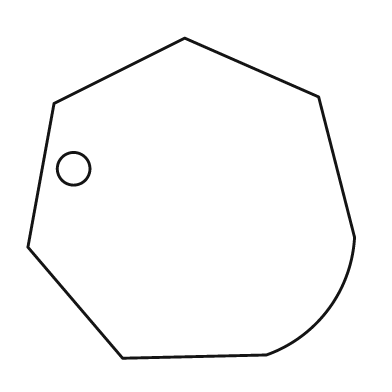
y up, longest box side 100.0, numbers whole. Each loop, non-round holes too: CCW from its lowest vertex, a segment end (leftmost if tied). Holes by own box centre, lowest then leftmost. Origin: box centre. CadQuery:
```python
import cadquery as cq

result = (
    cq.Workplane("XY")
    .moveTo(-21.0, -49.0)
    .lineTo(23.0, -48.0)
    .threePointArc((42.0, -34.0), (50.0, -12.0))
    .lineTo(39.0, 31.0)
    .lineTo(-2.0, 49.0)
    .lineTo(-42.0, 29.0)
    .lineTo(-50.0, -15.0)
    .close()
    .moveTo(-36.0, 9.0)
    .circle(5.0)
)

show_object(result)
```